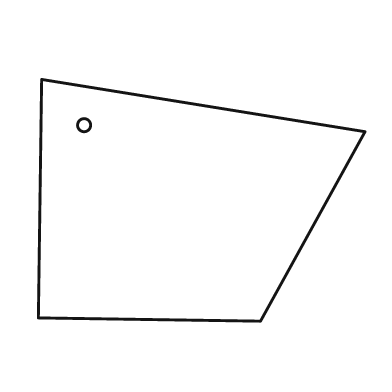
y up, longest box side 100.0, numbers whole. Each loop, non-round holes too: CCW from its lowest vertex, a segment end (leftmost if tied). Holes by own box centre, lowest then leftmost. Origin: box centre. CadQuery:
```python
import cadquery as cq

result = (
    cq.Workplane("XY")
    .moveTo(18.0, -37.0)
    .lineTo(50.0, 21.0)
    .lineTo(-49.0, 37.0)
    .lineTo(-50.0, -36.0)
    .close()
    .moveTo(-36.0, 23.0)
    .circle(2.0)
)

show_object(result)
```